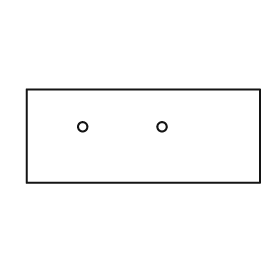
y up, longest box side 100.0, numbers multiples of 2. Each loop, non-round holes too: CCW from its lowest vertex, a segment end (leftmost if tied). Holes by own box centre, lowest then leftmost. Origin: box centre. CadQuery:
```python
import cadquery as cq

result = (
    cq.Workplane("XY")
    .moveTo(-50.0, -20.0)
    .lineTo(50.0, -20.0)
    .lineTo(50.0, 20.0)
    .lineTo(-50.0, 20.0)
    .close()
    .moveTo(-26.0, 4.0)
    .circle(2.0)
    .moveTo(8.0, 4.0)
    .circle(2.0)
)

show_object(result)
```